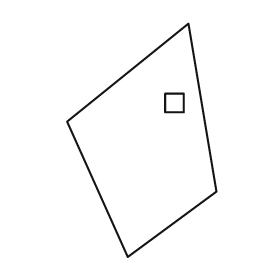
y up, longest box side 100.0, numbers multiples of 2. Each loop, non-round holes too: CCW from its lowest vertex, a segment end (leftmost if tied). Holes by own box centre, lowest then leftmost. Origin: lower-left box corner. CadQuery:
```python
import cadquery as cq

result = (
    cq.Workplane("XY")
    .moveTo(26.0, 0.0)
    .lineTo(64.0, 28.0)
    .lineTo(52.0, 100.0)
    .lineTo(0.0, 58.0)
    .close()
    .moveTo(42.0, 62.0)
    .lineTo(50.0, 62.0)
    .lineTo(50.0, 70.0)
    .lineTo(42.0, 70.0)
    .close()
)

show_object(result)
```